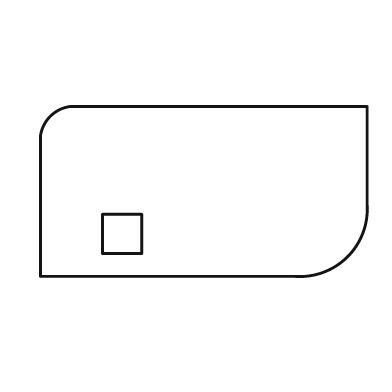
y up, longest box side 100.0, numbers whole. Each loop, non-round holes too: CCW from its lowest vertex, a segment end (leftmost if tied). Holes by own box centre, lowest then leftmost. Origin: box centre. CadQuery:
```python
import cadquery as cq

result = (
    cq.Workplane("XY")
    .moveTo(-50.0, -26.0)
    .lineTo(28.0, -26.0)
    .threePointArc((44.0, -20.0), (50.0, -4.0))
    .lineTo(50.0, 26.0)
    .lineTo(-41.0, 26.0)
    .threePointArc((-47.0, 23.0), (-50.0, 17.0))
    .close()
    .moveTo(-31.0, -19.0)
    .lineTo(-19.0, -19.0)
    .lineTo(-19.0, -7.0)
    .lineTo(-31.0, -7.0)
    .close()
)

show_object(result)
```